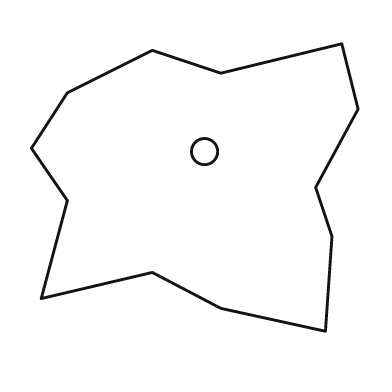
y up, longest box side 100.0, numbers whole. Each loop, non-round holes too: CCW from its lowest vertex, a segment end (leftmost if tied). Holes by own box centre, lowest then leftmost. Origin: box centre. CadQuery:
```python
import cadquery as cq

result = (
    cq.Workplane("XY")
    .moveTo(40.0, -44.0)
    .lineTo(42.0, -15.0)
    .lineTo(37.0, 0.0)
    .lineTo(50.0, 24.0)
    .lineTo(45.0, 44.0)
    .lineTo(8.0, 35.0)
    .lineTo(-13.0, 42.0)
    .lineTo(-39.0, 29.0)
    .lineTo(-50.0, 12.0)
    .lineTo(-39.0, -4.0)
    .lineTo(-47.0, -34.0)
    .lineTo(-13.0, -26.0)
    .lineTo(8.0, -37.0)
    .close()
    .moveTo(3.0, 11.0)
    .circle(4.0)
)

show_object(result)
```